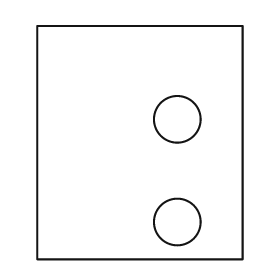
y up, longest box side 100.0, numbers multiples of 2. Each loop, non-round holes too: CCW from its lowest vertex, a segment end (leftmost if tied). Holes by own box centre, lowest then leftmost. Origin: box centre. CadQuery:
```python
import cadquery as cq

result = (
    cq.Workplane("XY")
    .moveTo(-44.0, -50.0)
    .lineTo(44.0, -50.0)
    .lineTo(44.0, 50.0)
    .lineTo(-44.0, 50.0)
    .close()
    .moveTo(16.0, -34.0)
    .circle(10.0)
    .moveTo(16.0, 10.0)
    .circle(10.0)
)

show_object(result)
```